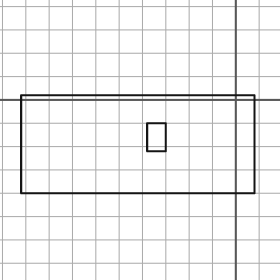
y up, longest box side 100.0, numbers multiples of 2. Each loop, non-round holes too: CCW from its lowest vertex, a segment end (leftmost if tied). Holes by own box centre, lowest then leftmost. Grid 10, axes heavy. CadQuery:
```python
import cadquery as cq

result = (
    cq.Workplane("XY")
    .moveTo(-92.0, -40.0)
    .lineTo(8.0, -40.0)
    .lineTo(8.0, 2.0)
    .lineTo(-92.0, 2.0)
    .close()
    .moveTo(-38.0, -22.0)
    .lineTo(-30.0, -22.0)
    .lineTo(-30.0, -10.0)
    .lineTo(-38.0, -10.0)
    .close()
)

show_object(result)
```